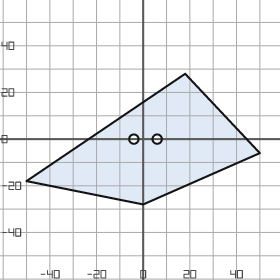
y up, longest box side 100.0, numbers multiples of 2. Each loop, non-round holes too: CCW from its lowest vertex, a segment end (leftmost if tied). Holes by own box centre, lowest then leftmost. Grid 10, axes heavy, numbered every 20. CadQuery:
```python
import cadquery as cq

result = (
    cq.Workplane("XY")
    .moveTo(0.0, -28.0)
    .lineTo(50.0, -6.0)
    .lineTo(18.0, 28.0)
    .lineTo(-50.0, -18.0)
    .close()
    .moveTo(-4.0, 0.0)
    .circle(2.0)
    .moveTo(6.0, 0.0)
    .circle(2.0)
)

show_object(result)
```